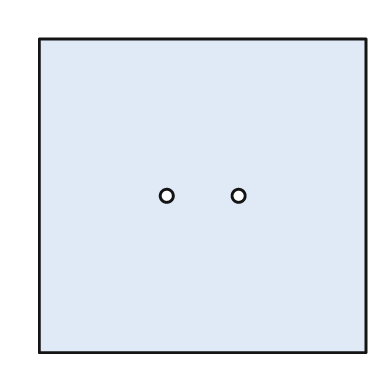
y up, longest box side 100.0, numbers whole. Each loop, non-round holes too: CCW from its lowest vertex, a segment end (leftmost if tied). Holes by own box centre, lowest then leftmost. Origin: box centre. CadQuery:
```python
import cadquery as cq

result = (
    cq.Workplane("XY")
    .moveTo(-50.0, -48.0)
    .lineTo(50.0, -48.0)
    .lineTo(50.0, 48.0)
    .lineTo(-50.0, 48.0)
    .close()
    .moveTo(-11.0, 0.0)
    .circle(2.0)
    .moveTo(11.0, 0.0)
    .circle(2.0)
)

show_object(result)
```